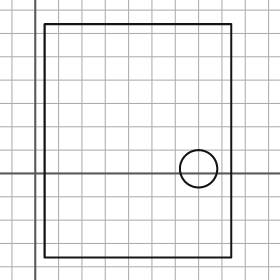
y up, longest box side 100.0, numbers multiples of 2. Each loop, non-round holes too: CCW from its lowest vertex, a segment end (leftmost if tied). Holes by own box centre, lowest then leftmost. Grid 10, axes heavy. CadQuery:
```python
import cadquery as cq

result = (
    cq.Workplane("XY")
    .moveTo(4.0, -36.0)
    .lineTo(84.0, -36.0)
    .lineTo(84.0, 64.0)
    .lineTo(4.0, 64.0)
    .close()
    .moveTo(70.0, 2.0)
    .circle(8.0)
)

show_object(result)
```